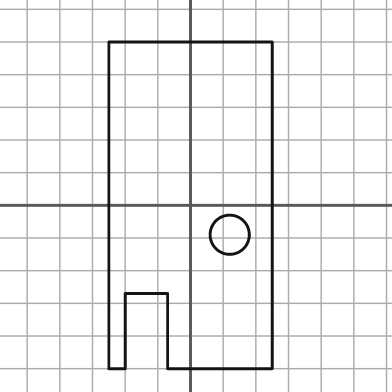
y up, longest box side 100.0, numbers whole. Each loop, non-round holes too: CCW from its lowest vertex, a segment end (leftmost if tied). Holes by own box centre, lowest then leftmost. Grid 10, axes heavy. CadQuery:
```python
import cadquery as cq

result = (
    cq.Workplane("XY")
    .moveTo(-25.0, -50.0)
    .lineTo(-20.0, -50.0)
    .lineTo(-20.0, -27.0)
    .lineTo(-7.0, -27.0)
    .lineTo(-7.0, -50.0)
    .lineTo(25.0, -50.0)
    .lineTo(25.0, 50.0)
    .lineTo(-25.0, 50.0)
    .close()
    .moveTo(12.0, -9.0)
    .circle(6.0)
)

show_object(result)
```